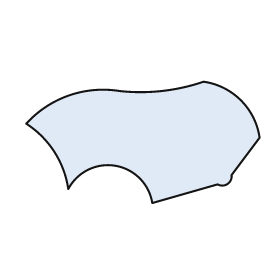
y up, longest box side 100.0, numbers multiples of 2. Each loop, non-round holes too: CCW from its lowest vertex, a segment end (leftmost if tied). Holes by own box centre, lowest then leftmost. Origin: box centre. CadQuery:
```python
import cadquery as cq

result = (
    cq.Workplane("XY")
    .moveTo(4.0, -26.0)
    .lineTo(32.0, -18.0)
    .threePointArc((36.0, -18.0), (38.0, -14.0))
    .lineTo(50.0, 2.0)
    .threePointArc((42.0, 18.0), (26.0, 26.0))
    .threePointArc((8.0, 22.0), (-10.0, 22.0))
    .threePointArc((-32.0, 20.0), (-50.0, 8.0))
    .threePointArc((-38.0, -4.0), (-32.0, -20.0))
    .threePointArc((-12.0, -10.0), (4.0, -26.0))
    .close()
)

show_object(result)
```